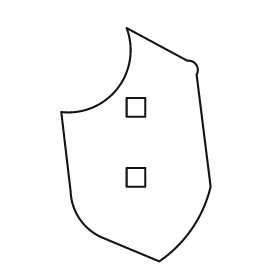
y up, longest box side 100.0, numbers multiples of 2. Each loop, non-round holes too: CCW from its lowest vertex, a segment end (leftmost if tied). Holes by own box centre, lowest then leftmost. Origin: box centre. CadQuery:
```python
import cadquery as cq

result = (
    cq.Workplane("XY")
    .moveTo(10.0, -50.0)
    .threePointArc((24.0, -36.0), (32.0, -18.0))
    .lineTo(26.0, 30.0)
    .threePointArc((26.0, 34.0), (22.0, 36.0))
    .lineTo(-4.0, 50.0)
    .threePointArc((-8.0, 24.0), (-32.0, 14.0))
    .lineTo(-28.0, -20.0)
    .threePointArc((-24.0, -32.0), (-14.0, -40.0))
    .close()
    .moveTo(-4.0, -18.0)
    .lineTo(4.0, -18.0)
    .lineTo(4.0, -10.0)
    .lineTo(-4.0, -10.0)
    .close()
    .moveTo(-4.0, 12.0)
    .lineTo(4.0, 12.0)
    .lineTo(4.0, 20.0)
    .lineTo(-4.0, 20.0)
    .close()
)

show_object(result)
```